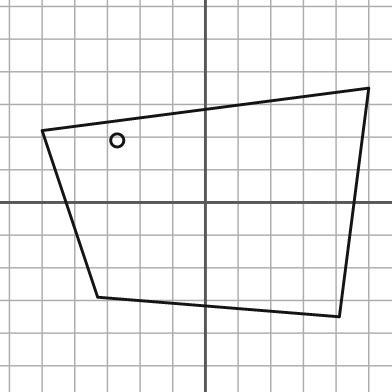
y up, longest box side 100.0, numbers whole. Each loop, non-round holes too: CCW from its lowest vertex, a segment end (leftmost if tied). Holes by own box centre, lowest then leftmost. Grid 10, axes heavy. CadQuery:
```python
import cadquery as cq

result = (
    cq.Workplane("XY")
    .moveTo(41.0, -35.0)
    .lineTo(50.0, 35.0)
    .lineTo(-50.0, 22.0)
    .lineTo(-33.0, -29.0)
    .close()
    .moveTo(-27.0, 19.0)
    .circle(2.0)
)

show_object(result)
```